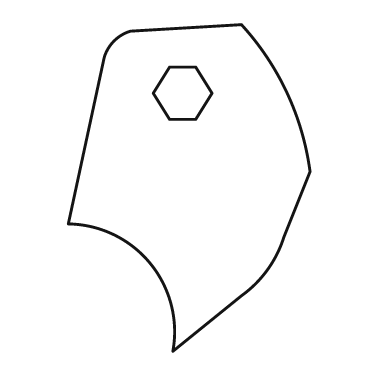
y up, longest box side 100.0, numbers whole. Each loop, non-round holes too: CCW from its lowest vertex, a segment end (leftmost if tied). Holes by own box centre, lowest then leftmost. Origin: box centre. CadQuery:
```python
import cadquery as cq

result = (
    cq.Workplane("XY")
    .moveTo(-5.0, -50.0)
    .lineTo(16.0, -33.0)
    .threePointArc((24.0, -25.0), (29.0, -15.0))
    .lineTo(37.0, 5.0)
    .threePointArc((30.0, 29.0), (16.0, 50.0))
    .lineTo(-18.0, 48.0)
    .threePointArc((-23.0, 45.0), (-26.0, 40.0))
    .lineTo(-37.0, -11.0)
    .threePointArc((-12.0, -23.0), (-5.0, -50.0))
    .close()
    .moveTo(-6.0, 21.0)
    .lineTo(2.0, 21.0)
    .lineTo(7.0, 29.0)
    .lineTo(2.0, 37.0)
    .lineTo(-6.0, 37.0)
    .lineTo(-11.0, 29.0)
    .close()
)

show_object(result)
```